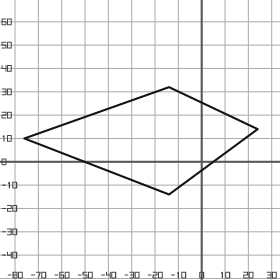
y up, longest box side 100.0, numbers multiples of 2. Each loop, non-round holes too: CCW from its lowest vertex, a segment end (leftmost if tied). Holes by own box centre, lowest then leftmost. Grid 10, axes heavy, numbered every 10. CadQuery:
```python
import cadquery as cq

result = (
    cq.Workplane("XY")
    .moveTo(-14.0, -14.0)
    .lineTo(24.0, 14.0)
    .lineTo(-14.0, 32.0)
    .lineTo(-76.0, 10.0)
    .close()
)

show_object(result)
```